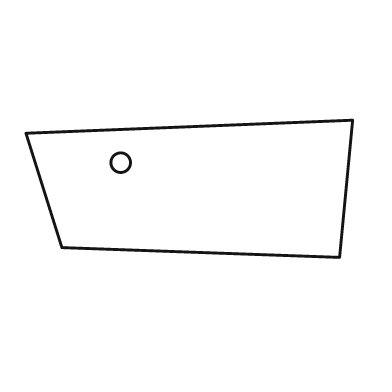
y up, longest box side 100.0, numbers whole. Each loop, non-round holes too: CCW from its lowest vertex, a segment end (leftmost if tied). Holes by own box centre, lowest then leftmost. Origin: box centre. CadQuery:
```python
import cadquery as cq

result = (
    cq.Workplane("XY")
    .moveTo(46.0, -21.0)
    .lineTo(50.0, 21.0)
    .lineTo(-50.0, 17.0)
    .lineTo(-39.0, -18.0)
    .close()
    .moveTo(-21.0, 8.0)
    .circle(3.0)
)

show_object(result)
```